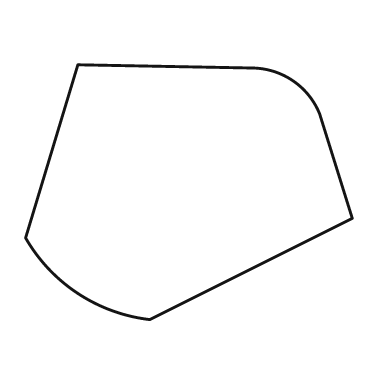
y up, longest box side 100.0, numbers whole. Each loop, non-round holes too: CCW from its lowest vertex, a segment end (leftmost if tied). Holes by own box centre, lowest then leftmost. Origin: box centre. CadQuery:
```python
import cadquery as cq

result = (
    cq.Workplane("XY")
    .moveTo(-12.0, -39.0)
    .lineTo(50.0, -8.0)
    .lineTo(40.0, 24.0)
    .threePointArc((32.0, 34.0), (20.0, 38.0))
    .lineTo(-34.0, 39.0)
    .lineTo(-50.0, -14.0)
    .threePointArc((-34.0, -31.0), (-12.0, -39.0))
    .close()
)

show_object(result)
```